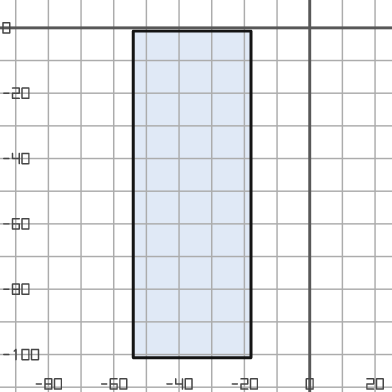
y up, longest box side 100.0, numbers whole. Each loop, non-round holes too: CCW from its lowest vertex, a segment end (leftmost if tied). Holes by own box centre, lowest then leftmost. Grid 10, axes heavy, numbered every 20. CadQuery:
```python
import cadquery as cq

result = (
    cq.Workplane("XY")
    .moveTo(-54.0, -101.0)
    .lineTo(-18.0, -101.0)
    .lineTo(-18.0, -1.0)
    .lineTo(-54.0, -1.0)
    .close()
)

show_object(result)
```